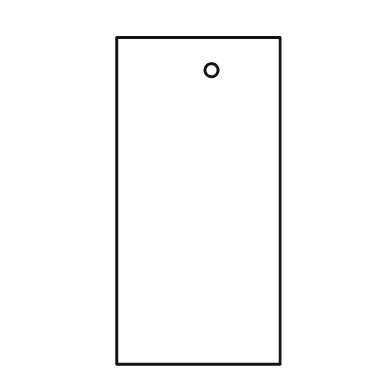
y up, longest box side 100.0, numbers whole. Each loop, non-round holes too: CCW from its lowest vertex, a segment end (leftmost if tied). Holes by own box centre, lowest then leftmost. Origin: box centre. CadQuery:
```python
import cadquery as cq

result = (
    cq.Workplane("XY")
    .moveTo(-25.0, -50.0)
    .lineTo(25.0, -50.0)
    .lineTo(25.0, 50.0)
    .lineTo(-25.0, 50.0)
    .close()
    .moveTo(4.0, 40.0)
    .circle(2.0)
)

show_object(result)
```